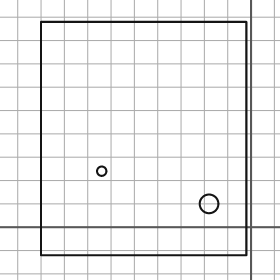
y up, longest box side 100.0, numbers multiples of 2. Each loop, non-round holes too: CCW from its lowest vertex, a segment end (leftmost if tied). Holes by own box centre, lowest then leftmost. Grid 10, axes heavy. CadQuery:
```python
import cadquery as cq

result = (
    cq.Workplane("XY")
    .moveTo(-90.0, -12.0)
    .lineTo(-2.0, -12.0)
    .lineTo(-2.0, 88.0)
    .lineTo(-90.0, 88.0)
    .close()
    .moveTo(-18.0, 10.0)
    .circle(4.0)
    .moveTo(-64.0, 24.0)
    .circle(2.0)
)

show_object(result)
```